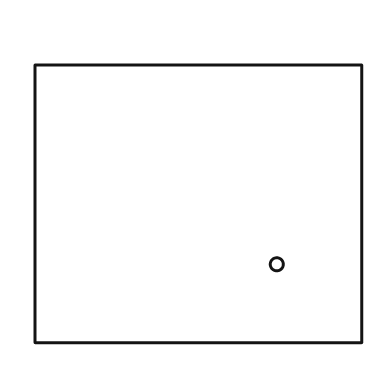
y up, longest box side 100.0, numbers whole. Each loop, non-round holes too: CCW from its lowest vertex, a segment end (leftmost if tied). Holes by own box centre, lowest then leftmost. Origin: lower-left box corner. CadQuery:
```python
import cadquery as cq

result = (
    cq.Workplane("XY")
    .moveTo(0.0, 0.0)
    .lineTo(100.0, 0.0)
    .lineTo(100.0, 85.0)
    .lineTo(0.0, 85.0)
    .close()
    .moveTo(74.0, 24.0)
    .circle(2.0)
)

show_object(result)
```